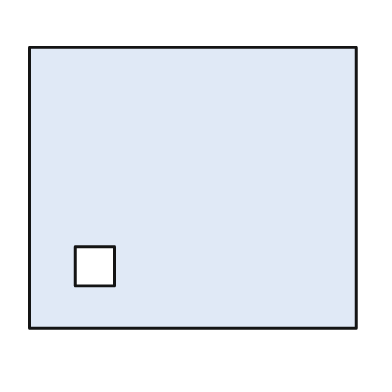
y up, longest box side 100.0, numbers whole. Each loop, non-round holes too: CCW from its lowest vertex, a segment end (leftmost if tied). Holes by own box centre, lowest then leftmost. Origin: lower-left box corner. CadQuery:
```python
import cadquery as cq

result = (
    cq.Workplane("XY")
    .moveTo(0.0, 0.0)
    .lineTo(100.0, 0.0)
    .lineTo(100.0, 86.0)
    .lineTo(0.0, 86.0)
    .close()
    .moveTo(14.0, 13.0)
    .lineTo(26.0, 13.0)
    .lineTo(26.0, 25.0)
    .lineTo(14.0, 25.0)
    .close()
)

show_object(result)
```